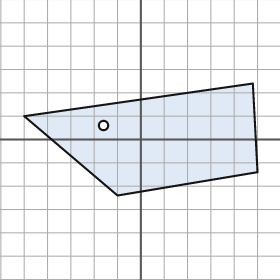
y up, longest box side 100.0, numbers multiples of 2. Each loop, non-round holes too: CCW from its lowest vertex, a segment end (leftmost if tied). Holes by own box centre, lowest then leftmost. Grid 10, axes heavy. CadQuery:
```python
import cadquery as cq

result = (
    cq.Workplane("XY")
    .moveTo(-10.0, -24.0)
    .lineTo(50.0, -14.0)
    .lineTo(48.0, 24.0)
    .lineTo(-50.0, 10.0)
    .close()
    .moveTo(-16.0, 6.0)
    .circle(2.0)
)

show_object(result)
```